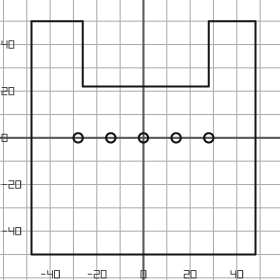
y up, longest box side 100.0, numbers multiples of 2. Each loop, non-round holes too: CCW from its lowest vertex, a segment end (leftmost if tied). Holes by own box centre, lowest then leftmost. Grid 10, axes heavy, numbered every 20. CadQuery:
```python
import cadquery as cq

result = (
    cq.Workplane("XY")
    .moveTo(-48.0, -50.0)
    .lineTo(48.0, -50.0)
    .lineTo(48.0, 50.0)
    .lineTo(28.0, 50.0)
    .lineTo(28.0, 22.0)
    .lineTo(-26.0, 22.0)
    .lineTo(-26.0, 50.0)
    .lineTo(-48.0, 50.0)
    .close()
    .moveTo(-28.0, 0.0)
    .circle(2.0)
    .moveTo(-14.0, 0.0)
    .circle(2.0)
    .moveTo(0.0, 0.0)
    .circle(2.0)
    .moveTo(14.0, 0.0)
    .circle(2.0)
    .moveTo(28.0, 0.0)
    .circle(2.0)
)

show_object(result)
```